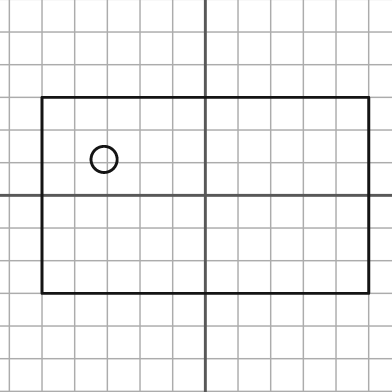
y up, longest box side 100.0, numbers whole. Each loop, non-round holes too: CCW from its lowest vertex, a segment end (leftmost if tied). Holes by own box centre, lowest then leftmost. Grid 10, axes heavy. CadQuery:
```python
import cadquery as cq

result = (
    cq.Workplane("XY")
    .moveTo(-50.0, -30.0)
    .lineTo(50.0, -30.0)
    .lineTo(50.0, 30.0)
    .lineTo(-50.0, 30.0)
    .close()
    .moveTo(-31.0, 11.0)
    .circle(4.0)
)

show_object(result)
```